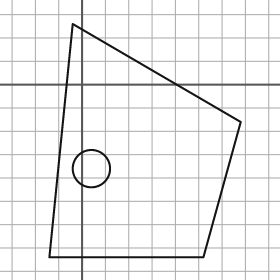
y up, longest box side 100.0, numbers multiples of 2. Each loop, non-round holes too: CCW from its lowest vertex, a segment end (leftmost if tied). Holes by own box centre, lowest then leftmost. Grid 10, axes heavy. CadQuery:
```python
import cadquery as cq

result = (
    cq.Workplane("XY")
    .moveTo(-14.0, -74.0)
    .lineTo(52.0, -74.0)
    .lineTo(68.0, -16.0)
    .lineTo(-4.0, 26.0)
    .close()
    .moveTo(4.0, -36.0)
    .circle(8.0)
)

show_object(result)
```